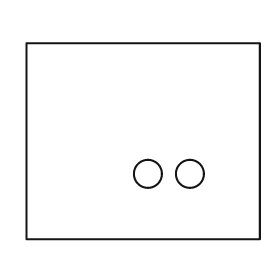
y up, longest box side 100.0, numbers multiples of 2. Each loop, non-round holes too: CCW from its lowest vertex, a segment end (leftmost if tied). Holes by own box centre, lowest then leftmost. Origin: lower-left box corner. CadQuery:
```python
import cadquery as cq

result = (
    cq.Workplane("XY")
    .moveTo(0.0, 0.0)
    .lineTo(100.0, 0.0)
    .lineTo(100.0, 84.0)
    .lineTo(0.0, 84.0)
    .close()
    .moveTo(52.0, 28.0)
    .circle(6.0)
    .moveTo(70.0, 28.0)
    .circle(6.0)
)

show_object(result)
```